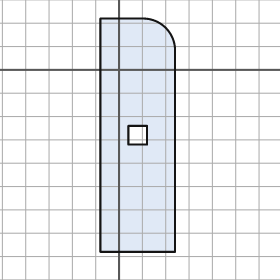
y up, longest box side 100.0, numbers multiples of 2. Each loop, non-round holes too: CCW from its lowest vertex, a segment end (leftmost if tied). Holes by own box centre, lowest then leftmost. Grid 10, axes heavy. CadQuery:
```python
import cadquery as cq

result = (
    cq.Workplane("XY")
    .moveTo(-8.0, -78.0)
    .lineTo(24.0, -78.0)
    .lineTo(24.0, 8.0)
    .threePointArc((20.0, 18.0), (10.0, 22.0))
    .lineTo(-8.0, 22.0)
    .close()
    .moveTo(4.0, -32.0)
    .lineTo(12.0, -32.0)
    .lineTo(12.0, -24.0)
    .lineTo(4.0, -24.0)
    .close()
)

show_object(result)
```